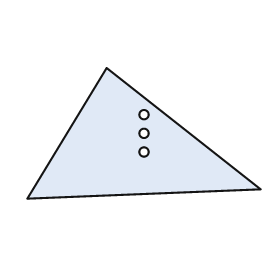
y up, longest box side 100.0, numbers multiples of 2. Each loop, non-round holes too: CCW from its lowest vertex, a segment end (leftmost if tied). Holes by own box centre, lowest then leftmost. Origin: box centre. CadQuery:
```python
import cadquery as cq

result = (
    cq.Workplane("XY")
    .moveTo(-50.0, -28.0)
    .lineTo(50.0, -24.0)
    .lineTo(-16.0, 28.0)
    .close()
    .moveTo(0.0, -8.0)
    .circle(2.0)
    .moveTo(0.0, 0.0)
    .circle(2.0)
    .moveTo(0.0, 8.0)
    .circle(2.0)
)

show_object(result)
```